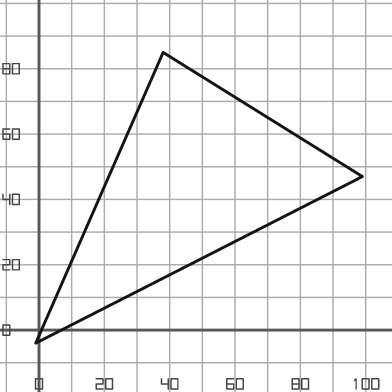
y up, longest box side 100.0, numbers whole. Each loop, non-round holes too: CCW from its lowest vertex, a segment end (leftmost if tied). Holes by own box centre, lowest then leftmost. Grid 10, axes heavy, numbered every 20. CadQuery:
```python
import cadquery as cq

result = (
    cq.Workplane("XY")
    .moveTo(-1.0, -4.0)
    .lineTo(99.0, 47.0)
    .lineTo(38.0, 85.0)
    .close()
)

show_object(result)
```